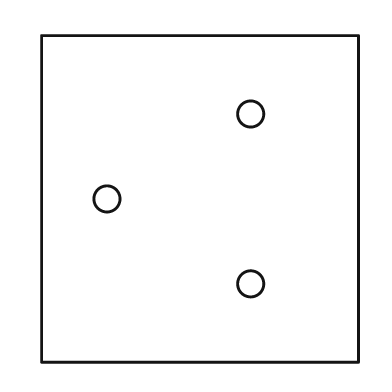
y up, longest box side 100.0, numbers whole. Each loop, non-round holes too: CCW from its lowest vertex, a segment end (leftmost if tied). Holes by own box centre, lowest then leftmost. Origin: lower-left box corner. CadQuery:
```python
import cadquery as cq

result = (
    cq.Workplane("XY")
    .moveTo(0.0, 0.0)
    .lineTo(97.0, 0.0)
    .lineTo(97.0, 100.0)
    .lineTo(0.0, 100.0)
    .close()
    .moveTo(64.0, 24.0)
    .circle(4.0)
    .moveTo(20.0, 50.0)
    .circle(4.0)
    .moveTo(64.0, 76.0)
    .circle(4.0)
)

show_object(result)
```